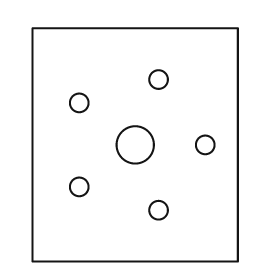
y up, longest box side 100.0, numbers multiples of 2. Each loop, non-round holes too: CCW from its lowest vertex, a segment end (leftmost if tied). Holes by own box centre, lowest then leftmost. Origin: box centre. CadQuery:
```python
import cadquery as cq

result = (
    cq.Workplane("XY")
    .moveTo(-44.0, -50.0)
    .lineTo(44.0, -50.0)
    .lineTo(44.0, 50.0)
    .lineTo(-44.0, 50.0)
    .close()
    .moveTo(10.0, -28.0)
    .circle(4.0)
    .moveTo(-24.0, -18.0)
    .circle(4.0)
    .moveTo(0.0, 0.0)
    .circle(8.0)
    .moveTo(30.0, 0.0)
    .circle(4.0)
    .moveTo(-24.0, 18.0)
    .circle(4.0)
    .moveTo(10.0, 28.0)
    .circle(4.0)
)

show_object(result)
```